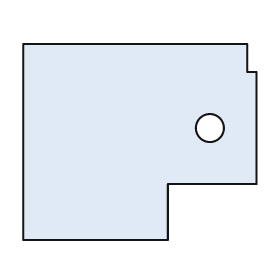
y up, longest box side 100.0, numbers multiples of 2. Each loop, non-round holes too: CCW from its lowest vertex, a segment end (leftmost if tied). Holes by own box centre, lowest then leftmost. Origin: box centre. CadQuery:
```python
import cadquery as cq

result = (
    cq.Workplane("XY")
    .moveTo(-50.0, -42.0)
    .lineTo(12.0, -42.0)
    .lineTo(12.0, -18.0)
    .lineTo(50.0, -18.0)
    .lineTo(50.0, 30.0)
    .lineTo(46.0, 30.0)
    .lineTo(46.0, 42.0)
    .lineTo(-50.0, 42.0)
    .close()
    .moveTo(30.0, 6.0)
    .circle(6.0)
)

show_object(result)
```